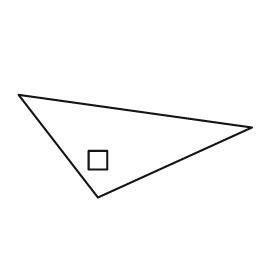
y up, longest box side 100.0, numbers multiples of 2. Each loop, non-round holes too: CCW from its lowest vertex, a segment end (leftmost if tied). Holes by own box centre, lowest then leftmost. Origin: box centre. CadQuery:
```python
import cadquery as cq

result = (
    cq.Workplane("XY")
    .moveTo(-16.0, -22.0)
    .lineTo(50.0, 8.0)
    .lineTo(-50.0, 22.0)
    .close()
    .moveTo(-20.0, -10.0)
    .lineTo(-12.0, -10.0)
    .lineTo(-12.0, -2.0)
    .lineTo(-20.0, -2.0)
    .close()
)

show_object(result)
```